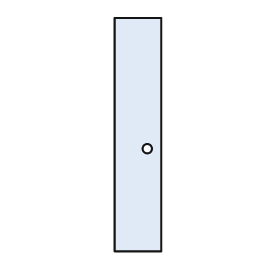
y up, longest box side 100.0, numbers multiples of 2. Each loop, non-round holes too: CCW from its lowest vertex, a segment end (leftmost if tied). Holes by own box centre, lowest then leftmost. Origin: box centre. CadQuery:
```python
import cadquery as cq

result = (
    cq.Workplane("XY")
    .moveTo(-10.0, -50.0)
    .lineTo(10.0, -50.0)
    .lineTo(10.0, 50.0)
    .lineTo(-10.0, 50.0)
    .close()
    .moveTo(4.0, -6.0)
    .circle(2.0)
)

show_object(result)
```